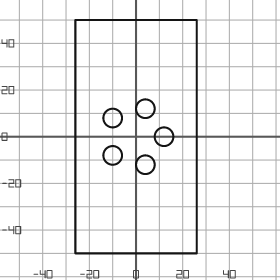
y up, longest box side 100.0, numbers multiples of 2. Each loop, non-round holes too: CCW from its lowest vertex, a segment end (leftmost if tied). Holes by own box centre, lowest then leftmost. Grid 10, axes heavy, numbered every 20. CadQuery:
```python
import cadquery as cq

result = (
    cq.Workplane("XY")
    .moveTo(-26.0, -50.0)
    .lineTo(26.0, -50.0)
    .lineTo(26.0, 50.0)
    .lineTo(-26.0, 50.0)
    .close()
    .moveTo(4.0, -12.0)
    .circle(4.0)
    .moveTo(-10.0, -8.0)
    .circle(4.0)
    .moveTo(12.0, 0.0)
    .circle(4.0)
    .moveTo(-10.0, 8.0)
    .circle(4.0)
    .moveTo(4.0, 12.0)
    .circle(4.0)
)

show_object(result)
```